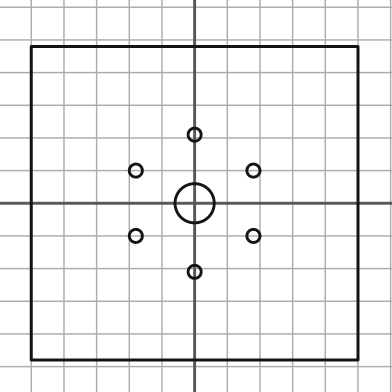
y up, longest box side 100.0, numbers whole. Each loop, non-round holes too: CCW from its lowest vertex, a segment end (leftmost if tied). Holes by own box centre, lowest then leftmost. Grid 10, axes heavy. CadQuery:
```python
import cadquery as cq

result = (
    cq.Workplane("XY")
    .moveTo(-50.0, -48.0)
    .lineTo(50.0, -48.0)
    .lineTo(50.0, 48.0)
    .lineTo(-50.0, 48.0)
    .close()
    .moveTo(0.0, -21.0)
    .circle(2.0)
    .moveTo(-18.0, -10.0)
    .circle(2.0)
    .moveTo(18.0, -10.0)
    .circle(2.0)
    .moveTo(0.0, 0.0)
    .circle(6.0)
    .moveTo(-18.0, 10.0)
    .circle(2.0)
    .moveTo(18.0, 10.0)
    .circle(2.0)
    .moveTo(0.0, 21.0)
    .circle(2.0)
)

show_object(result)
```